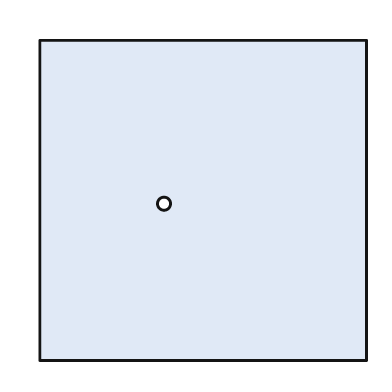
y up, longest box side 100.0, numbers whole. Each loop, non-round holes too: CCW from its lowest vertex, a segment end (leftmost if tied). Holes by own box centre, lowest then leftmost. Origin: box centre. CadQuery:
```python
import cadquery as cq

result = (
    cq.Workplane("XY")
    .moveTo(-50.0, -49.0)
    .lineTo(50.0, -49.0)
    .lineTo(50.0, 49.0)
    .lineTo(-50.0, 49.0)
    .close()
    .moveTo(-12.0, -1.0)
    .circle(2.0)
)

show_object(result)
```